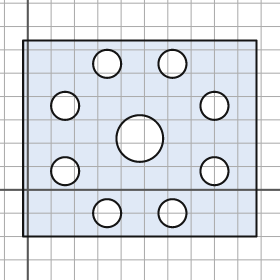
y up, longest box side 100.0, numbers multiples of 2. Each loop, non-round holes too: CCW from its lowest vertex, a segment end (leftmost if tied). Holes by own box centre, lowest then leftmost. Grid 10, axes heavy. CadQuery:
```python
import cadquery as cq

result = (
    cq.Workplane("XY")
    .moveTo(-2.0, -20.0)
    .lineTo(98.0, -20.0)
    .lineTo(98.0, 64.0)
    .lineTo(-2.0, 64.0)
    .close()
    .moveTo(34.0, -10.0)
    .circle(6.0)
    .moveTo(62.0, -10.0)
    .circle(6.0)
    .moveTo(16.0, 8.0)
    .circle(6.0)
    .moveTo(80.0, 8.0)
    .circle(6.0)
    .moveTo(48.0, 22.0)
    .circle(10.0)
    .moveTo(16.0, 36.0)
    .circle(6.0)
    .moveTo(80.0, 36.0)
    .circle(6.0)
    .moveTo(34.0, 54.0)
    .circle(6.0)
    .moveTo(62.0, 54.0)
    .circle(6.0)
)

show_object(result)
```